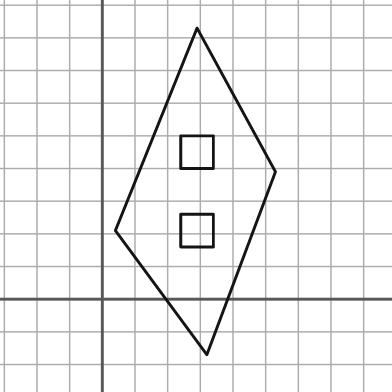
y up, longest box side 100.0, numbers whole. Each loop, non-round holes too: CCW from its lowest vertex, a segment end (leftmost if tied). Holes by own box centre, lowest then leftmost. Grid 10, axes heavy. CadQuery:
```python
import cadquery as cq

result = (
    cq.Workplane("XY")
    .moveTo(32.0, -17.0)
    .lineTo(53.0, 39.0)
    .lineTo(29.0, 83.0)
    .lineTo(4.0, 21.0)
    .close()
    .moveTo(24.0, 16.0)
    .lineTo(34.0, 16.0)
    .lineTo(34.0, 26.0)
    .lineTo(24.0, 26.0)
    .close()
    .moveTo(24.0, 40.0)
    .lineTo(34.0, 40.0)
    .lineTo(34.0, 50.0)
    .lineTo(24.0, 50.0)
    .close()
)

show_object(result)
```